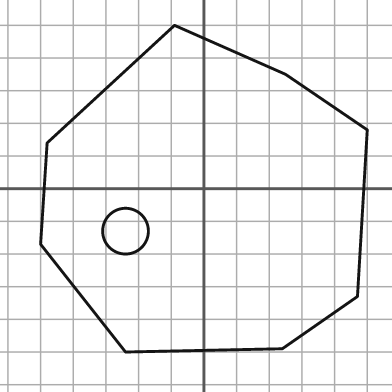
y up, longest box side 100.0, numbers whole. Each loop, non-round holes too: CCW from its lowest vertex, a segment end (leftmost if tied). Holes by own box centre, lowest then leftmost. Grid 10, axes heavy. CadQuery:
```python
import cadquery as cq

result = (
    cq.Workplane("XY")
    .moveTo(-24.0, -50.0)
    .lineTo(24.0, -49.0)
    .lineTo(47.0, -33.0)
    .lineTo(50.0, 18.0)
    .lineTo(25.0, 35.0)
    .lineTo(-9.0, 50.0)
    .lineTo(-48.0, 14.0)
    .lineTo(-50.0, -17.0)
    .close()
    .moveTo(-24.0, -13.0)
    .circle(7.0)
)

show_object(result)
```